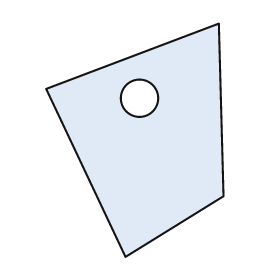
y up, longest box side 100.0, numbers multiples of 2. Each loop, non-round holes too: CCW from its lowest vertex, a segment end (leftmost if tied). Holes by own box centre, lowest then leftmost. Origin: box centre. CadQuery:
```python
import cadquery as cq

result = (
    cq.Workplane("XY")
    .moveTo(-4.0, -50.0)
    .lineTo(38.0, -24.0)
    .lineTo(36.0, 50.0)
    .lineTo(-38.0, 22.0)
    .close()
    .moveTo(2.0, 18.0)
    .circle(8.0)
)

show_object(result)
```